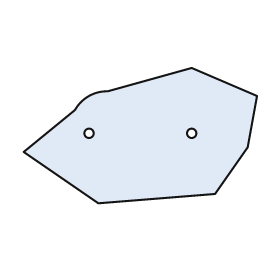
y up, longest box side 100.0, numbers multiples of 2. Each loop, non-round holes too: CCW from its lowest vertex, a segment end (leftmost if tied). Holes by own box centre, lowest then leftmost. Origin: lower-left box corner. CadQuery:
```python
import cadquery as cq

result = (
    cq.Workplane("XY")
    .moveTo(32.0, 0.0)
    .lineTo(82.0, 4.0)
    .lineTo(96.0, 24.0)
    .lineTo(100.0, 46.0)
    .lineTo(72.0, 58.0)
    .lineTo(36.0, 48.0)
    .threePointArc((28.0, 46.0), (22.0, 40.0))
    .lineTo(0.0, 22.0)
    .close()
    .moveTo(28.0, 30.0)
    .circle(2.0)
    .moveTo(72.0, 30.0)
    .circle(2.0)
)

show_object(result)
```